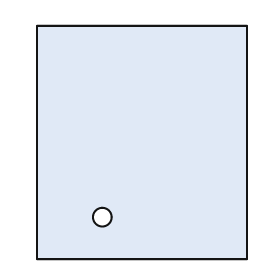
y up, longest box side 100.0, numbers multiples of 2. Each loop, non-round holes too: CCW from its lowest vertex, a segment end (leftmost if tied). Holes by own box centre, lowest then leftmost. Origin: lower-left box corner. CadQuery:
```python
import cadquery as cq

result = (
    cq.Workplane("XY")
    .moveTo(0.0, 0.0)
    .lineTo(90.0, 0.0)
    .lineTo(90.0, 100.0)
    .lineTo(0.0, 100.0)
    .close()
    .moveTo(28.0, 18.0)
    .circle(4.0)
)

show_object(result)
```